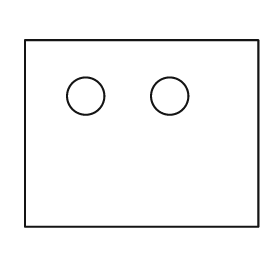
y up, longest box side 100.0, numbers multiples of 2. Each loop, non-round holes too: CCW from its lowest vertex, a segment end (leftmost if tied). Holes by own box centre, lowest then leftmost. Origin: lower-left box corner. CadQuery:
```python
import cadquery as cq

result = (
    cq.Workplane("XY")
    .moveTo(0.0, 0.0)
    .lineTo(100.0, 0.0)
    .lineTo(100.0, 80.0)
    .lineTo(0.0, 80.0)
    .close()
    .moveTo(26.0, 56.0)
    .circle(8.0)
    .moveTo(62.0, 56.0)
    .circle(8.0)
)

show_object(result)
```